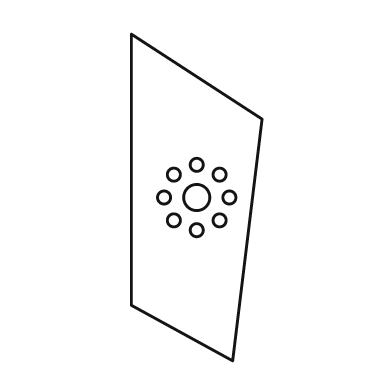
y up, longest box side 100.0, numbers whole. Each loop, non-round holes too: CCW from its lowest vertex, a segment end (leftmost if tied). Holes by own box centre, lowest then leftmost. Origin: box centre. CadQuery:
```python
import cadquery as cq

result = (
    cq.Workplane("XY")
    .moveTo(11.0, -50.0)
    .lineTo(20.0, 24.0)
    .lineTo(-20.0, 50.0)
    .lineTo(-20.0, -33.0)
    .close()
    .moveTo(0.0, -10.0)
    .circle(2.0)
    .moveTo(-7.0, -7.0)
    .circle(2.0)
    .moveTo(7.0, -7.0)
    .circle(2.0)
    .moveTo(-10.0, 0.0)
    .circle(2.0)
    .moveTo(0.0, 0.0)
    .circle(4.0)
    .moveTo(10.0, 0.0)
    .circle(2.0)
    .moveTo(-7.0, 7.0)
    .circle(2.0)
    .moveTo(7.0, 7.0)
    .circle(2.0)
    .moveTo(0.0, 10.0)
    .circle(2.0)
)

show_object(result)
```